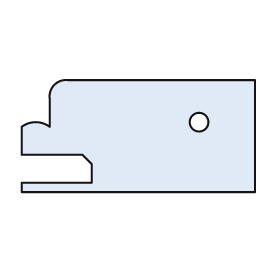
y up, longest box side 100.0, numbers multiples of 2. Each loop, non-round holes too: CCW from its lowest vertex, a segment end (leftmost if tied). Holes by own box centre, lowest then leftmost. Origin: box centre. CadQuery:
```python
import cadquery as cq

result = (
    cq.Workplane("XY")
    .moveTo(-50.0, -24.0)
    .lineTo(50.0, -24.0)
    .lineTo(50.0, 24.0)
    .lineTo(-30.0, 24.0)
    .threePointArc((-36.0, 22.0), (-38.0, 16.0))
    .lineTo(-38.0, 4.0)
    .threePointArc((-44.0, 6.0), (-50.0, 4.0))
    .lineTo(-50.0, -8.0)
    .lineTo(-24.0, -8.0)
    .lineTo(-20.0, -12.0)
    .lineTo(-20.0, -20.0)
    .lineTo(-50.0, -20.0)
    .close()
    .moveTo(26.0, 6.0)
    .circle(4.0)
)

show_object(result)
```